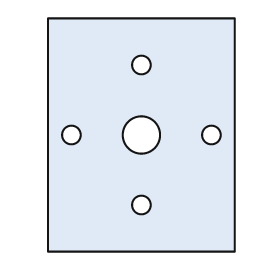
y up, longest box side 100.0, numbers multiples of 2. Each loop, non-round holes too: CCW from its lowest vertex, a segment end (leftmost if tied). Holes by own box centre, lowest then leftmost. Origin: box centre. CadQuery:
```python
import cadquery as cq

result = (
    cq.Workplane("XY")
    .moveTo(-40.0, -50.0)
    .lineTo(40.0, -50.0)
    .lineTo(40.0, 50.0)
    .lineTo(-40.0, 50.0)
    .close()
    .moveTo(0.0, -30.0)
    .circle(4.0)
    .moveTo(-30.0, 0.0)
    .circle(4.0)
    .moveTo(0.0, 0.0)
    .circle(8.0)
    .moveTo(30.0, 0.0)
    .circle(4.0)
    .moveTo(0.0, 30.0)
    .circle(4.0)
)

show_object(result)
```